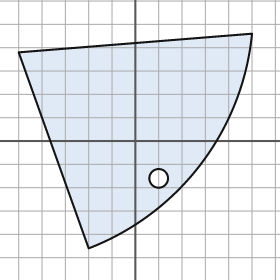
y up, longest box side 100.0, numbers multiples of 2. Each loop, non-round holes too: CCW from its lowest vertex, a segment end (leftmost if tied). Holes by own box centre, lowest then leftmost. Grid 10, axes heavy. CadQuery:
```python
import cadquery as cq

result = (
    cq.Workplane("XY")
    .moveTo(-20.0, -46.0)
    .threePointArc((28.0, -10.0), (50.0, 46.0))
    .lineTo(-50.0, 38.0)
    .close()
    .moveTo(10.0, -16.0)
    .circle(4.0)
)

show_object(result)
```